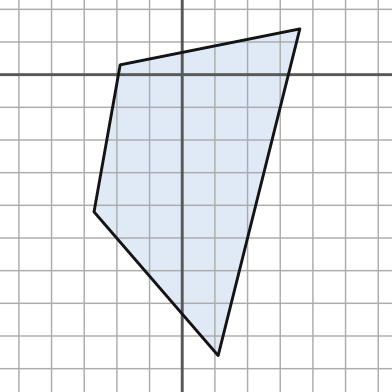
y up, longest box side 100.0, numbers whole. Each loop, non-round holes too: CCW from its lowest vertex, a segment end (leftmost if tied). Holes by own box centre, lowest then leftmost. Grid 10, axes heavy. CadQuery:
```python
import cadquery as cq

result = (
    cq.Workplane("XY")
    .moveTo(11.0, -86.0)
    .lineTo(36.0, 14.0)
    .lineTo(-19.0, 3.0)
    .lineTo(-27.0, -42.0)
    .close()
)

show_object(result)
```